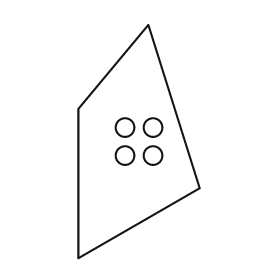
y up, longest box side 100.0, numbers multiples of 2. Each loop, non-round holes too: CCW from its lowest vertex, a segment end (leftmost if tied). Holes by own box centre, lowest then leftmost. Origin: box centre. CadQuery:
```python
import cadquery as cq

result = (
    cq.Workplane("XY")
    .moveTo(-26.0, -50.0)
    .lineTo(26.0, -20.0)
    .lineTo(4.0, 50.0)
    .lineTo(-26.0, 14.0)
    .close()
    .moveTo(-6.0, -6.0)
    .circle(4.0)
    .moveTo(6.0, -6.0)
    .circle(4.0)
    .moveTo(-6.0, 6.0)
    .circle(4.0)
    .moveTo(6.0, 6.0)
    .circle(4.0)
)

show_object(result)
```